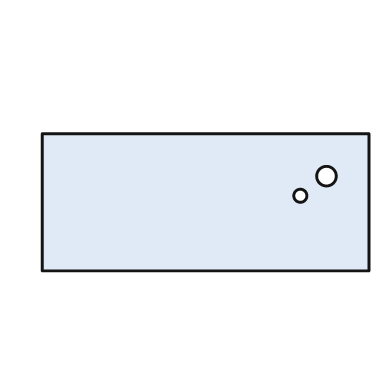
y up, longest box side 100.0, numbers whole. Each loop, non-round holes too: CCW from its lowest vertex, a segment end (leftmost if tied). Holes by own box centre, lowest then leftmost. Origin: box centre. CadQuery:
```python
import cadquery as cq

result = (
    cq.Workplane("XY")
    .moveTo(-50.0, -21.0)
    .lineTo(50.0, -21.0)
    .lineTo(50.0, 21.0)
    .lineTo(-50.0, 21.0)
    .close()
    .moveTo(29.0, 2.0)
    .circle(2.0)
    .moveTo(37.0, 8.0)
    .circle(3.0)
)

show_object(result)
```